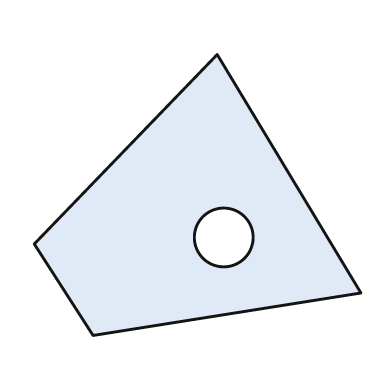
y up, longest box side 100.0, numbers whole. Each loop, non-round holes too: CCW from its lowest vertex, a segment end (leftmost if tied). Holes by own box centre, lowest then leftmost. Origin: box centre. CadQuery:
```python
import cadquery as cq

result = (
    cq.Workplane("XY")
    .moveTo(-32.0, -43.0)
    .lineTo(50.0, -30.0)
    .lineTo(6.0, 43.0)
    .lineTo(-50.0, -15.0)
    .close()
    .moveTo(8.0, -13.0)
    .circle(9.0)
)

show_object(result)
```